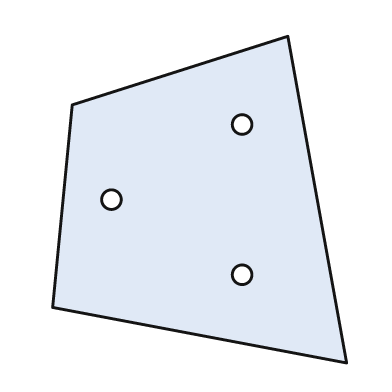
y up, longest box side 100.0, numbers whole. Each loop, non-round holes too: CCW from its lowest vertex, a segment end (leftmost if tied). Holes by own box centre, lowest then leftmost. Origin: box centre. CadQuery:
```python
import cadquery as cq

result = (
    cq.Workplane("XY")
    .moveTo(45.0, -50.0)
    .lineTo(27.0, 50.0)
    .lineTo(-39.0, 29.0)
    .lineTo(-45.0, -33.0)
    .close()
    .moveTo(13.0, -23.0)
    .circle(3.0)
    .moveTo(-27.0, 0.0)
    .circle(3.0)
    .moveTo(13.0, 23.0)
    .circle(3.0)
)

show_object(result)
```